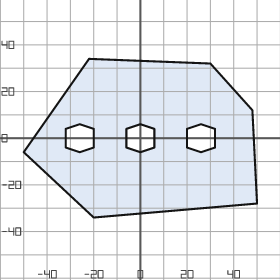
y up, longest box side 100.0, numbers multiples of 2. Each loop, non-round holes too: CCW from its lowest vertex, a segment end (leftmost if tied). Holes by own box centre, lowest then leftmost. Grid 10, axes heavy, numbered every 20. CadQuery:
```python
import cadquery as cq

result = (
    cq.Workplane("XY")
    .moveTo(-20.0, -34.0)
    .lineTo(50.0, -28.0)
    .lineTo(48.0, 12.0)
    .lineTo(30.0, 32.0)
    .lineTo(-22.0, 34.0)
    .lineTo(-50.0, -6.0)
    .close()
    .moveTo(-26.0, -6.0)
    .lineTo(-20.0, -4.0)
    .lineTo(-20.0, 4.0)
    .lineTo(-26.0, 6.0)
    .lineTo(-32.0, 4.0)
    .lineTo(-32.0, -4.0)
    .close()
    .moveTo(0.0, -6.0)
    .lineTo(6.0, -4.0)
    .lineTo(6.0, 4.0)
    .lineTo(0.0, 6.0)
    .lineTo(-6.0, 4.0)
    .lineTo(-6.0, -4.0)
    .close()
    .moveTo(26.0, -6.0)
    .lineTo(32.0, -4.0)
    .lineTo(32.0, 4.0)
    .lineTo(26.0, 6.0)
    .lineTo(20.0, 4.0)
    .lineTo(20.0, -4.0)
    .close()
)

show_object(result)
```